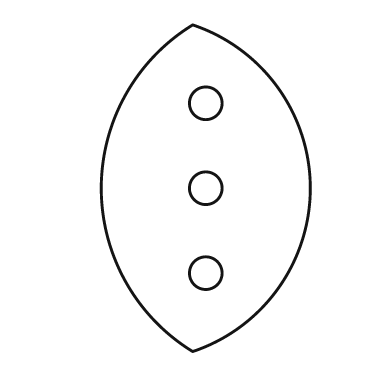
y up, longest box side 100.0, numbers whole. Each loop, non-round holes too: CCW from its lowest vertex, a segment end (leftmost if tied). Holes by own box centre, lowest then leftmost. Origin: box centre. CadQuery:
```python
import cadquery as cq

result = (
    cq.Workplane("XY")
    .moveTo(-4.0, -50.0)
    .threePointArc((32.0, 0.0), (-4.0, 50.0))
    .threePointArc((-32.0, 0.0), (-4.0, -50.0))
    .close()
    .moveTo(0.0, -26.0)
    .circle(5.0)
    .moveTo(0.0, 0.0)
    .circle(5.0)
    .moveTo(0.0, 26.0)
    .circle(5.0)
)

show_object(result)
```